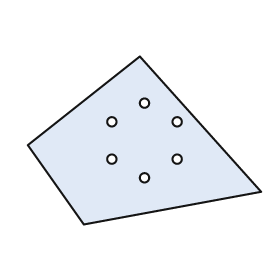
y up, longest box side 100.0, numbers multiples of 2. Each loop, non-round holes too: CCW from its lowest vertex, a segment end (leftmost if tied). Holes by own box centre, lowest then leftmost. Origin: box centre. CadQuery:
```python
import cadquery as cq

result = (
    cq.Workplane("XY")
    .moveTo(-26.0, -36.0)
    .lineTo(50.0, -22.0)
    .lineTo(-2.0, 36.0)
    .lineTo(-50.0, -2.0)
    .close()
    .moveTo(0.0, -16.0)
    .circle(2.0)
    .moveTo(-14.0, -8.0)
    .circle(2.0)
    .moveTo(14.0, -8.0)
    .circle(2.0)
    .moveTo(-14.0, 8.0)
    .circle(2.0)
    .moveTo(14.0, 8.0)
    .circle(2.0)
    .moveTo(0.0, 16.0)
    .circle(2.0)
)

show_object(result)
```